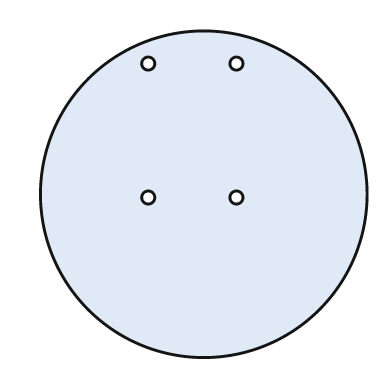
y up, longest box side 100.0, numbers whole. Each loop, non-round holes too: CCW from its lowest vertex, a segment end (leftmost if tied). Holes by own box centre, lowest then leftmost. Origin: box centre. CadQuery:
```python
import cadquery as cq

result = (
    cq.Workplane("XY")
    .moveTo(0.0, 0.0)
    .circle(50.0)
    .moveTo(-17.0, -1.0)
    .circle(2.0)
    .moveTo(10.0, -1.0)
    .circle(2.0)
    .moveTo(-17.0, 40.0)
    .circle(2.0)
    .moveTo(10.0, 40.0)
    .circle(2.0)
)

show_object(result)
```